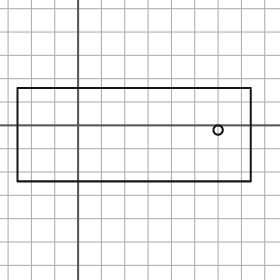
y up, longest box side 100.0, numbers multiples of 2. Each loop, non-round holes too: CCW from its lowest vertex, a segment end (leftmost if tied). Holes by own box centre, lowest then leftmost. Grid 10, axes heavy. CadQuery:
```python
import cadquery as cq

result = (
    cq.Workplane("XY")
    .moveTo(-26.0, -24.0)
    .lineTo(74.0, -24.0)
    .lineTo(74.0, 16.0)
    .lineTo(-26.0, 16.0)
    .close()
    .moveTo(60.0, -2.0)
    .circle(2.0)
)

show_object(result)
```